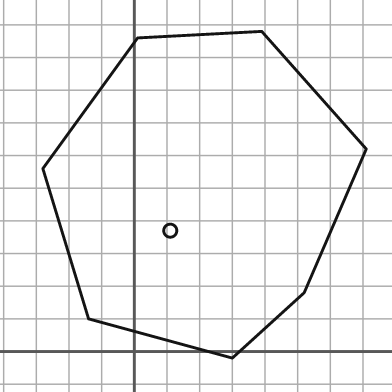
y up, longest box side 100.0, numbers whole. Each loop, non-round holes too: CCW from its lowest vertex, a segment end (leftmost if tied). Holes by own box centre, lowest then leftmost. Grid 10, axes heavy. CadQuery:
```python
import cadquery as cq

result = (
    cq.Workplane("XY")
    .moveTo(30.0, -2.0)
    .lineTo(52.0, 18.0)
    .lineTo(71.0, 62.0)
    .lineTo(39.0, 98.0)
    .lineTo(1.0, 96.0)
    .lineTo(-28.0, 56.0)
    .lineTo(-14.0, 10.0)
    .close()
    .moveTo(11.0, 37.0)
    .circle(2.0)
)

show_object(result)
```